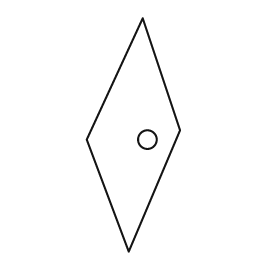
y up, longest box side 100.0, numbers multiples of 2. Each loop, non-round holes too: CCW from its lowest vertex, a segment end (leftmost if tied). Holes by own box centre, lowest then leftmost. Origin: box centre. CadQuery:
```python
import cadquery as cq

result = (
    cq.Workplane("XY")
    .moveTo(-2.0, -50.0)
    .lineTo(20.0, 2.0)
    .lineTo(4.0, 50.0)
    .lineTo(-20.0, -2.0)
    .close()
    .moveTo(6.0, -2.0)
    .circle(4.0)
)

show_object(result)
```